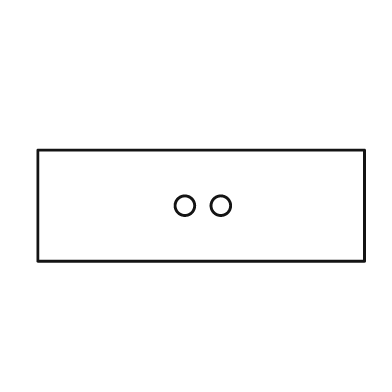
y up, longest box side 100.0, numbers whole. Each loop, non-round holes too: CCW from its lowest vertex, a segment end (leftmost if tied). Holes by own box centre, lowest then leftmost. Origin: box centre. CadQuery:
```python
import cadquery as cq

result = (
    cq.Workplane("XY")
    .moveTo(-50.0, -17.0)
    .lineTo(50.0, -17.0)
    .lineTo(50.0, 17.0)
    .lineTo(-50.0, 17.0)
    .close()
    .moveTo(-5.0, 0.0)
    .circle(3.0)
    .moveTo(6.0, 0.0)
    .circle(3.0)
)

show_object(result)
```